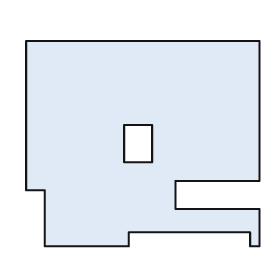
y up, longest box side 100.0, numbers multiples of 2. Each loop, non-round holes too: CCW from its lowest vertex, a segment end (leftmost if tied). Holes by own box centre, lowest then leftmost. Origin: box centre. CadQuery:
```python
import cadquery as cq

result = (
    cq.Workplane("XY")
    .moveTo(-42.0, -44.0)
    .lineTo(-6.0, -44.0)
    .lineTo(-6.0, -38.0)
    .lineTo(46.0, -38.0)
    .lineTo(46.0, -44.0)
    .lineTo(50.0, -44.0)
    .lineTo(50.0, -28.0)
    .lineTo(14.0, -28.0)
    .lineTo(14.0, -16.0)
    .lineTo(50.0, -16.0)
    .lineTo(50.0, 44.0)
    .lineTo(-50.0, 44.0)
    .lineTo(-50.0, -20.0)
    .lineTo(-42.0, -20.0)
    .close()
    .moveTo(-8.0, -8.0)
    .lineTo(4.0, -8.0)
    .lineTo(4.0, 8.0)
    .lineTo(-8.0, 8.0)
    .close()
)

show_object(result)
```